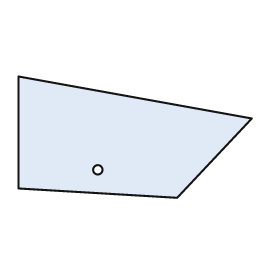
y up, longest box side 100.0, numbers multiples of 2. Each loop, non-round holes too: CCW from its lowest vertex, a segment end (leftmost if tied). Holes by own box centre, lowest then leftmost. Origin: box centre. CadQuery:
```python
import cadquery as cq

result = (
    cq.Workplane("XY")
    .moveTo(18.0, -26.0)
    .lineTo(50.0, 8.0)
    .lineTo(-50.0, 26.0)
    .lineTo(-50.0, -22.0)
    .close()
    .moveTo(-16.0, -14.0)
    .circle(2.0)
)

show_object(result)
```